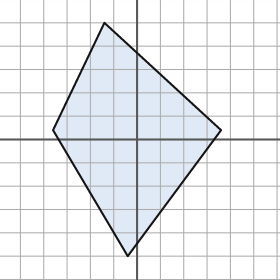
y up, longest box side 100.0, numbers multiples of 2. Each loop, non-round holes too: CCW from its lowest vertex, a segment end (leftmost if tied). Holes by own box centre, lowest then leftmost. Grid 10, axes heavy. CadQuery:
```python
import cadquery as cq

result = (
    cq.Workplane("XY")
    .moveTo(-4.0, -50.0)
    .lineTo(36.0, 4.0)
    .lineTo(-14.0, 50.0)
    .lineTo(-36.0, 4.0)
    .close()
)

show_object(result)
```